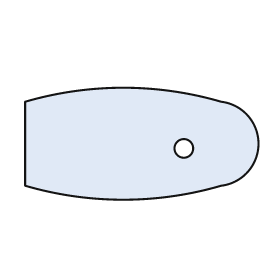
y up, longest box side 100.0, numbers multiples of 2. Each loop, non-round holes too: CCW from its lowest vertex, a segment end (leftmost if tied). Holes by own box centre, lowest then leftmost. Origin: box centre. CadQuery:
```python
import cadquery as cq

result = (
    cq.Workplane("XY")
    .moveTo(-50.0, -18.0)
    .threePointArc((-8.0, -24.0), (34.0, -18.0))
    .threePointArc((50.0, 0.0), (34.0, 18.0))
    .threePointArc((-8.0, 24.0), (-50.0, 18.0))
    .close()
    .moveTo(18.0, -2.0)
    .circle(4.0)
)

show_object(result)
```